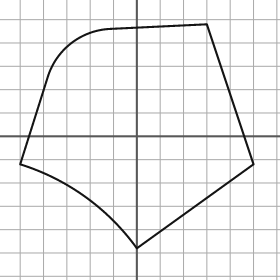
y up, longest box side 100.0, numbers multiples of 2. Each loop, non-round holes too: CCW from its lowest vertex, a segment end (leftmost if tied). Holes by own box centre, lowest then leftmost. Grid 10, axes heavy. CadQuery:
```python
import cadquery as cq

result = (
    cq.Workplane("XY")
    .moveTo(0.0, -48.0)
    .lineTo(50.0, -12.0)
    .lineTo(30.0, 48.0)
    .lineTo(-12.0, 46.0)
    .threePointArc((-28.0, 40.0), (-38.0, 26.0))
    .lineTo(-50.0, -12.0)
    .threePointArc((-22.0, -26.0), (0.0, -48.0))
    .close()
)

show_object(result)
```